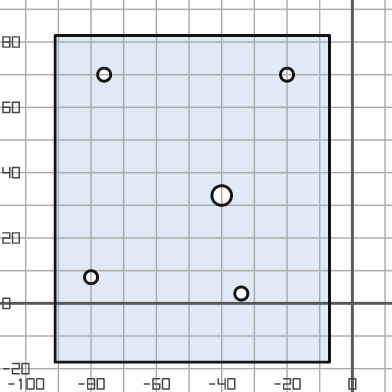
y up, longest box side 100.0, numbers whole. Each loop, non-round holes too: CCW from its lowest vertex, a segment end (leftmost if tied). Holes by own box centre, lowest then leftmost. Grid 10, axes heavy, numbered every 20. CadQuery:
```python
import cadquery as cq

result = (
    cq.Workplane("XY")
    .moveTo(-91.0, -18.0)
    .lineTo(-7.0, -18.0)
    .lineTo(-7.0, 82.0)
    .lineTo(-91.0, 82.0)
    .close()
    .moveTo(-34.0, 3.0)
    .circle(2.0)
    .moveTo(-80.0, 8.0)
    .circle(2.0)
    .moveTo(-40.0, 33.0)
    .circle(3.0)
    .moveTo(-76.0, 70.0)
    .circle(2.0)
    .moveTo(-20.0, 70.0)
    .circle(2.0)
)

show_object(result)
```